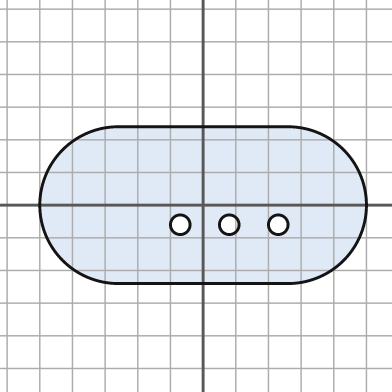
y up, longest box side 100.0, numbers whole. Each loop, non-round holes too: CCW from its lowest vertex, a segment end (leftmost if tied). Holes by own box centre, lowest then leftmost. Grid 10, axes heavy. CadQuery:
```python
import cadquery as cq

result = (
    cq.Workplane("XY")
    .moveTo(-26.0, -24.0)
    .lineTo(26.0, -24.0)
    .threePointArc((50.0, 0.0), (26.0, 24.0))
    .lineTo(-26.0, 24.0)
    .threePointArc((-50.0, 0.0), (-26.0, -24.0))
    .close()
    .moveTo(-7.0, -6.0)
    .circle(3.0)
    .moveTo(8.0, -6.0)
    .circle(3.0)
    .moveTo(23.0, -6.0)
    .circle(3.0)
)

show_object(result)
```